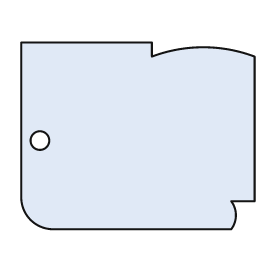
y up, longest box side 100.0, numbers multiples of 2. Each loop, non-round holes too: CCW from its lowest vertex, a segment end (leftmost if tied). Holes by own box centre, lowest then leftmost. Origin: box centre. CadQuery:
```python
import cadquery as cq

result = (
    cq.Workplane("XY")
    .moveTo(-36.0, -40.0)
    .lineTo(40.0, -40.0)
    .threePointArc((42.0, -34.0), (40.0, -28.0))
    .lineTo(50.0, -28.0)
    .lineTo(50.0, 34.0)
    .threePointArc((28.0, 38.0), (6.0, 34.0))
    .lineTo(6.0, 40.0)
    .lineTo(-50.0, 40.0)
    .lineTo(-50.0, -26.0)
    .threePointArc((-46.0, -36.0), (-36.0, -40.0))
    .close()
    .moveTo(-42.0, -2.0)
    .circle(4.0)
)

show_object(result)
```